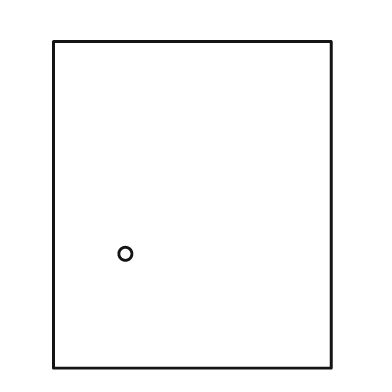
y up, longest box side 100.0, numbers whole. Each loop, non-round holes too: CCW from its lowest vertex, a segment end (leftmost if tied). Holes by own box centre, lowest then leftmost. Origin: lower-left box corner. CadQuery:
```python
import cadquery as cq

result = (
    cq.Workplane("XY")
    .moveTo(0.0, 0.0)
    .lineTo(85.0, 0.0)
    .lineTo(85.0, 100.0)
    .lineTo(0.0, 100.0)
    .close()
    .moveTo(22.0, 35.0)
    .circle(2.0)
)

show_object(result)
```